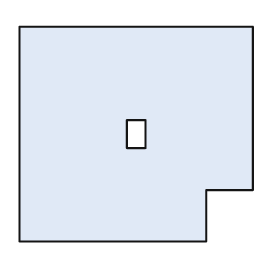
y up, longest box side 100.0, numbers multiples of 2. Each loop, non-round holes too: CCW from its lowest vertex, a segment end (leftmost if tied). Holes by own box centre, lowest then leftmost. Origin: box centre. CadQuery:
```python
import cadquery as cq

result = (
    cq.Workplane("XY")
    .moveTo(-50.0, -46.0)
    .lineTo(30.0, -46.0)
    .lineTo(30.0, -24.0)
    .lineTo(50.0, -24.0)
    .lineTo(50.0, 46.0)
    .lineTo(-50.0, 46.0)
    .close()
    .moveTo(-4.0, -6.0)
    .lineTo(4.0, -6.0)
    .lineTo(4.0, 6.0)
    .lineTo(-4.0, 6.0)
    .close()
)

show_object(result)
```